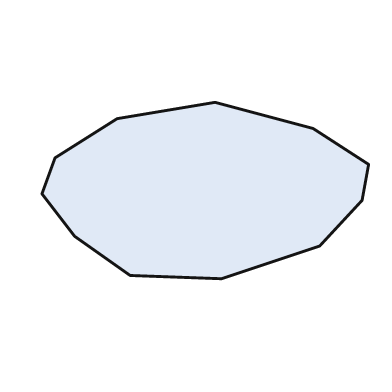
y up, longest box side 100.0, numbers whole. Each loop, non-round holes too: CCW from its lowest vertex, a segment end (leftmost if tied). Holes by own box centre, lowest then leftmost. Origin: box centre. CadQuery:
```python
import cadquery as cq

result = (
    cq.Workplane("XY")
    .moveTo(5.0, -27.0)
    .lineTo(35.0, -17.0)
    .lineTo(48.0, -3.0)
    .lineTo(50.0, 8.0)
    .lineTo(33.0, 19.0)
    .lineTo(3.0, 27.0)
    .lineTo(-27.0, 22.0)
    .lineTo(-46.0, 10.0)
    .lineTo(-50.0, -1.0)
    .lineTo(-40.0, -14.0)
    .lineTo(-23.0, -26.0)
    .close()
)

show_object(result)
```